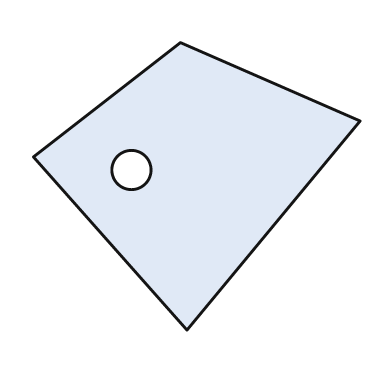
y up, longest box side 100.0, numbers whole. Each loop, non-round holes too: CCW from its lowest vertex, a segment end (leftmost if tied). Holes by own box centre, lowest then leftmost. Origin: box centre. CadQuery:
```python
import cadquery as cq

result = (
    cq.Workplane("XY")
    .moveTo(-3.0, -44.0)
    .lineTo(50.0, 20.0)
    .lineTo(-5.0, 44.0)
    .lineTo(-50.0, 9.0)
    .close()
    .moveTo(-20.0, 5.0)
    .circle(6.0)
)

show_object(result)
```